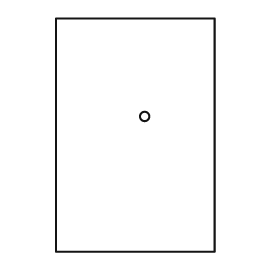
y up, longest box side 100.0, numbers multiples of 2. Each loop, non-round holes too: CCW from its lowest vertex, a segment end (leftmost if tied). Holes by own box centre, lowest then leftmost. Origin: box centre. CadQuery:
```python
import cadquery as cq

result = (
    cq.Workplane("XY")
    .moveTo(-34.0, -50.0)
    .lineTo(34.0, -50.0)
    .lineTo(34.0, 50.0)
    .lineTo(-34.0, 50.0)
    .close()
    .moveTo(4.0, 8.0)
    .circle(2.0)
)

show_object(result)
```